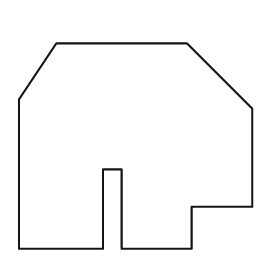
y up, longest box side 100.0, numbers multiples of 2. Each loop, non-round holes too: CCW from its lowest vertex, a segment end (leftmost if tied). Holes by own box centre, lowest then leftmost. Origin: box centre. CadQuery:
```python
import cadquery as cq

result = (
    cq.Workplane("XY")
    .moveTo(-50.0, -44.0)
    .lineTo(-14.0, -44.0)
    .lineTo(-14.0, -10.0)
    .lineTo(-6.0, -10.0)
    .lineTo(-6.0, -44.0)
    .lineTo(24.0, -44.0)
    .lineTo(24.0, -26.0)
    .lineTo(50.0, -26.0)
    .lineTo(50.0, 16.0)
    .lineTo(22.0, 44.0)
    .lineTo(-34.0, 44.0)
    .lineTo(-50.0, 20.0)
    .close()
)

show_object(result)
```